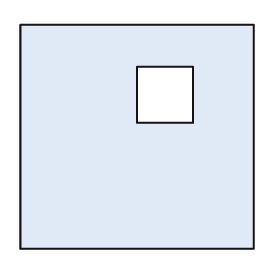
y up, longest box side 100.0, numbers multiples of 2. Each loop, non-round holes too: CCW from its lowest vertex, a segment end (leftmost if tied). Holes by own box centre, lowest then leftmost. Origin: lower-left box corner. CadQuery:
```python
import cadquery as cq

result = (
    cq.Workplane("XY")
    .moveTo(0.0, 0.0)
    .lineTo(100.0, 0.0)
    .lineTo(100.0, 96.0)
    .lineTo(0.0, 96.0)
    .close()
    .moveTo(50.0, 54.0)
    .lineTo(74.0, 54.0)
    .lineTo(74.0, 78.0)
    .lineTo(50.0, 78.0)
    .close()
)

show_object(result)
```